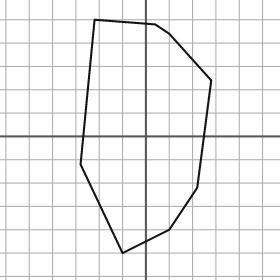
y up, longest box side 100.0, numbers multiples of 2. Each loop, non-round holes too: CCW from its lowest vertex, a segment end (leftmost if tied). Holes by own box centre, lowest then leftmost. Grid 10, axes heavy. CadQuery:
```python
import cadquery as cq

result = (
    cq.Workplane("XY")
    .moveTo(-10.0, -50.0)
    .lineTo(10.0, -40.0)
    .lineTo(22.0, -22.0)
    .lineTo(28.0, 24.0)
    .lineTo(10.0, 44.0)
    .lineTo(4.0, 48.0)
    .lineTo(-22.0, 50.0)
    .lineTo(-28.0, -12.0)
    .close()
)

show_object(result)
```